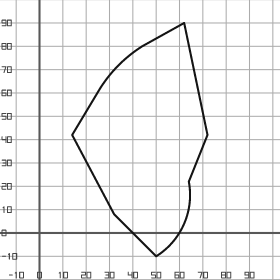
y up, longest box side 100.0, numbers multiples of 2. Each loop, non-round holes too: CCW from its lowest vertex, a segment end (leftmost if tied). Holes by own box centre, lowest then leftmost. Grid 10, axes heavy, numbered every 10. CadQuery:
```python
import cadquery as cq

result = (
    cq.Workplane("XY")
    .moveTo(50.0, -10.0)
    .threePointArc((62.0, 4.0), (64.0, 22.0))
    .lineTo(72.0, 42.0)
    .lineTo(62.0, 90.0)
    .lineTo(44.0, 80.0)
    .threePointArc((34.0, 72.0), (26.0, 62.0))
    .lineTo(14.0, 42.0)
    .lineTo(32.0, 8.0)
    .close()
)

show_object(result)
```